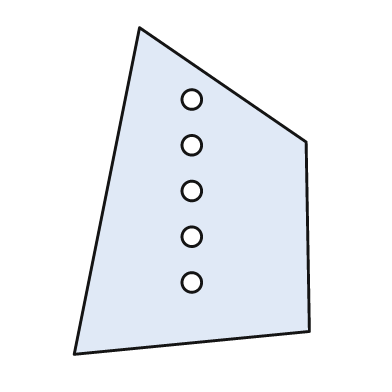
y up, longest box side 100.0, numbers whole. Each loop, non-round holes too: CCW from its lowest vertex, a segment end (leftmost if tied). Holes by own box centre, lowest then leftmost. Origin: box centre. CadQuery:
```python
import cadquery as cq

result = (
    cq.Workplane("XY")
    .moveTo(-36.0, -50.0)
    .lineTo(36.0, -43.0)
    .lineTo(35.0, 15.0)
    .lineTo(-16.0, 50.0)
    .close()
    .moveTo(0.0, -28.0)
    .circle(3.0)
    .moveTo(0.0, -14.0)
    .circle(3.0)
    .moveTo(0.0, 0.0)
    .circle(3.0)
    .moveTo(0.0, 14.0)
    .circle(3.0)
    .moveTo(0.0, 28.0)
    .circle(3.0)
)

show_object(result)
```